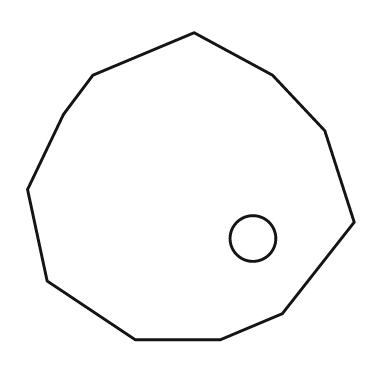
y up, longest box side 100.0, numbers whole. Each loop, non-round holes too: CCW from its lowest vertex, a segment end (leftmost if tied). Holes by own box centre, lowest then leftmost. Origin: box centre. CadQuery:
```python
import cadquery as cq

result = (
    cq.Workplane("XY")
    .moveTo(-17.0, -47.0)
    .lineTo(9.0, -47.0)
    .lineTo(28.0, -39.0)
    .lineTo(50.0, -11.0)
    .lineTo(41.0, 17.0)
    .lineTo(25.0, 34.0)
    .lineTo(1.0, 47.0)
    .lineTo(-30.0, 34.0)
    .lineTo(-39.0, 22.0)
    .lineTo(-50.0, -1.0)
    .lineTo(-44.0, -29.0)
    .close()
    .moveTo(19.0, -16.0)
    .circle(7.0)
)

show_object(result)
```